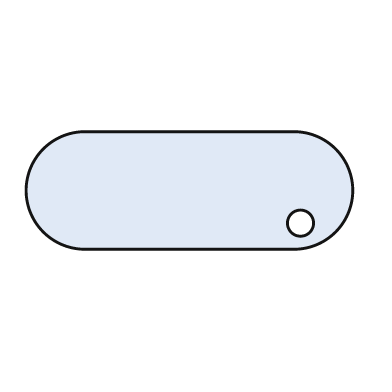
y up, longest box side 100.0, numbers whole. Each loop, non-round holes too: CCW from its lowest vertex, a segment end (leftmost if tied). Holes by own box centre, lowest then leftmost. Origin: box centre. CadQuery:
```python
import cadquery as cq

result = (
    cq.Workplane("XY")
    .moveTo(-32.0, -18.0)
    .lineTo(32.0, -18.0)
    .threePointArc((50.0, 0.0), (32.0, 18.0))
    .lineTo(-32.0, 18.0)
    .threePointArc((-50.0, 0.0), (-32.0, -18.0))
    .close()
    .moveTo(34.0, -10.0)
    .circle(4.0)
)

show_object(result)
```